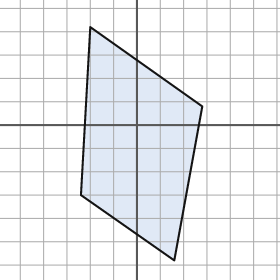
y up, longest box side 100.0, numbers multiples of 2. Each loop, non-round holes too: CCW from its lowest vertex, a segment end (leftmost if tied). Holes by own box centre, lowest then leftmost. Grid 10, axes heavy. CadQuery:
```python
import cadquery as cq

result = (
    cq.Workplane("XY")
    .moveTo(16.0, -58.0)
    .lineTo(28.0, 8.0)
    .lineTo(-20.0, 42.0)
    .lineTo(-24.0, -30.0)
    .close()
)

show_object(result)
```